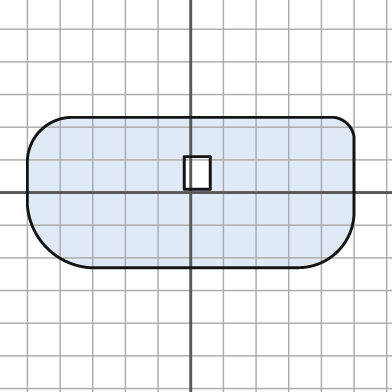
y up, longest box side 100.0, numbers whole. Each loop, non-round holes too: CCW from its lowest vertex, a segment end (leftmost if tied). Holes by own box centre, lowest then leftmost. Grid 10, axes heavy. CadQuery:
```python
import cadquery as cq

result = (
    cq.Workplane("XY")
    .moveTo(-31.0, -23.0)
    .lineTo(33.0, -23.0)
    .threePointArc((45.0, -18.0), (50.0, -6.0))
    .lineTo(50.0, 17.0)
    .threePointArc((48.0, 21.0), (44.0, 23.0))
    .lineTo(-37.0, 23.0)
    .threePointArc((-46.0, 19.0), (-50.0, 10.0))
    .lineTo(-50.0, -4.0)
    .threePointArc((-44.0, -17.0), (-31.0, -23.0))
    .close()
    .moveTo(-2.0, 1.0)
    .lineTo(6.0, 1.0)
    .lineTo(6.0, 11.0)
    .lineTo(-2.0, 11.0)
    .close()
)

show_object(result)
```